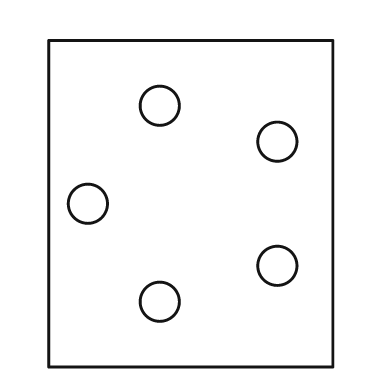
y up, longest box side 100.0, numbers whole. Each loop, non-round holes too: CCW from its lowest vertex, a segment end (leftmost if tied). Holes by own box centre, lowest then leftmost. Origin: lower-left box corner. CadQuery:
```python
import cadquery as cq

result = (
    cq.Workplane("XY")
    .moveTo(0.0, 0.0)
    .lineTo(87.0, 0.0)
    .lineTo(87.0, 100.0)
    .lineTo(0.0, 100.0)
    .close()
    .moveTo(34.0, 20.0)
    .circle(6.0)
    .moveTo(70.0, 31.0)
    .circle(6.0)
    .moveTo(12.0, 50.0)
    .circle(6.0)
    .moveTo(70.0, 69.0)
    .circle(6.0)
    .moveTo(34.0, 80.0)
    .circle(6.0)
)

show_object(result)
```